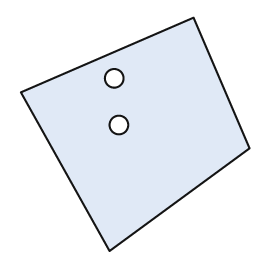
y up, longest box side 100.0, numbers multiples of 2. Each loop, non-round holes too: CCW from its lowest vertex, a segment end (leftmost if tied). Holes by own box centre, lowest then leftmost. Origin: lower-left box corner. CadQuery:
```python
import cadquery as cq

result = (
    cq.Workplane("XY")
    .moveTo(38.0, 0.0)
    .lineTo(98.0, 44.0)
    .lineTo(74.0, 100.0)
    .lineTo(0.0, 68.0)
    .close()
    .moveTo(42.0, 54.0)
    .circle(4.0)
    .moveTo(40.0, 74.0)
    .circle(4.0)
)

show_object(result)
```